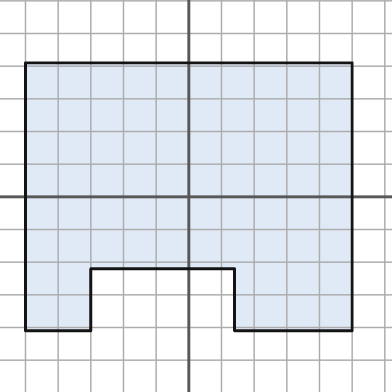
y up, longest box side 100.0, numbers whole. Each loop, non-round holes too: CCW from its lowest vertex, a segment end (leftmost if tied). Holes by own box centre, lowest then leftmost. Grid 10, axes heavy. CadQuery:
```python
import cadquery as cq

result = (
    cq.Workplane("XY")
    .moveTo(-50.0, -41.0)
    .lineTo(-30.0, -41.0)
    .lineTo(-30.0, -22.0)
    .lineTo(14.0, -22.0)
    .lineTo(14.0, -41.0)
    .lineTo(50.0, -41.0)
    .lineTo(50.0, 41.0)
    .lineTo(-50.0, 41.0)
    .close()
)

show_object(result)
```